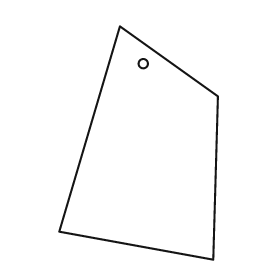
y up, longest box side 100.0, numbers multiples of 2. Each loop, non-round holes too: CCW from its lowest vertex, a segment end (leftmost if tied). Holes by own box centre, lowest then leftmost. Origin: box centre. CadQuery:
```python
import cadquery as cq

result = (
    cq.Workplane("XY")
    .moveTo(32.0, -50.0)
    .lineTo(34.0, 20.0)
    .lineTo(-8.0, 50.0)
    .lineTo(-34.0, -38.0)
    .close()
    .moveTo(2.0, 34.0)
    .circle(2.0)
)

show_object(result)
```